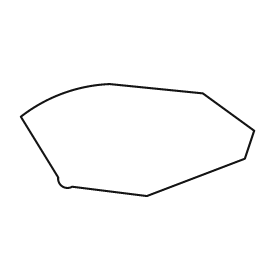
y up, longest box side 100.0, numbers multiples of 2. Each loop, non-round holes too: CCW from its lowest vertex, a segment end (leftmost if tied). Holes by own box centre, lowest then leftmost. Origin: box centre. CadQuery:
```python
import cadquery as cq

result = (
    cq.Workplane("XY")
    .moveTo(4.0, -24.0)
    .lineTo(46.0, -8.0)
    .lineTo(50.0, 4.0)
    .lineTo(28.0, 20.0)
    .lineTo(-12.0, 24.0)
    .threePointArc((-32.0, 20.0), (-50.0, 10.0))
    .lineTo(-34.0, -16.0)
    .threePointArc((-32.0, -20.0), (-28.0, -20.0))
    .close()
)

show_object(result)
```